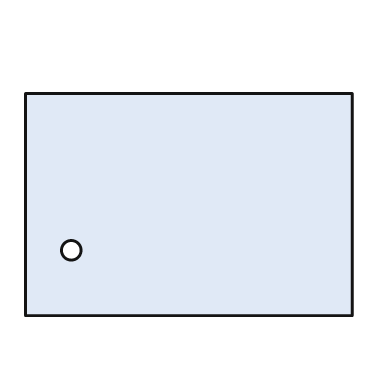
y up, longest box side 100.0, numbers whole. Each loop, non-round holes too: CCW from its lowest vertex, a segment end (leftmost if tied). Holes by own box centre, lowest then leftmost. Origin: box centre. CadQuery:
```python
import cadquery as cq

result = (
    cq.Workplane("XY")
    .moveTo(-50.0, -34.0)
    .lineTo(50.0, -34.0)
    .lineTo(50.0, 34.0)
    .lineTo(-50.0, 34.0)
    .close()
    .moveTo(-36.0, -14.0)
    .circle(3.0)
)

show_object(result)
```